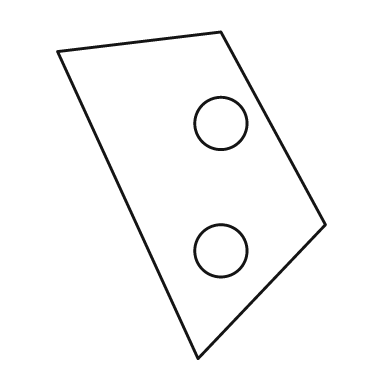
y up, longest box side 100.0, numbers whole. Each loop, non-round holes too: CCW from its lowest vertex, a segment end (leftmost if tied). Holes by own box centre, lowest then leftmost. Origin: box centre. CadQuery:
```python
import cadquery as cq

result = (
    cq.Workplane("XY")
    .moveTo(2.0, -50.0)
    .lineTo(41.0, -9.0)
    .lineTo(9.0, 50.0)
    .lineTo(-41.0, 44.0)
    .close()
    .moveTo(9.0, -17.0)
    .circle(8.0)
    .moveTo(9.0, 22.0)
    .circle(8.0)
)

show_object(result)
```